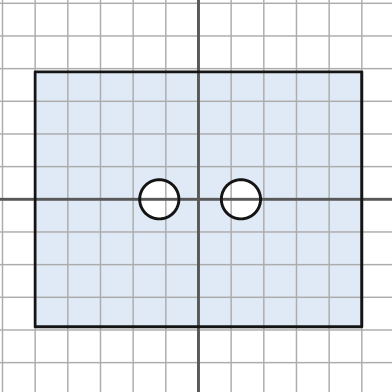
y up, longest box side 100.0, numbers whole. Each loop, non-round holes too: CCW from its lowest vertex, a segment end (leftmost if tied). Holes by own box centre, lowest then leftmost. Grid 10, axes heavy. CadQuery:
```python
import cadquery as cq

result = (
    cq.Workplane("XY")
    .moveTo(-50.0, -39.0)
    .lineTo(50.0, -39.0)
    .lineTo(50.0, 39.0)
    .lineTo(-50.0, 39.0)
    .close()
    .moveTo(-12.0, 0.0)
    .circle(6.0)
    .moveTo(13.0, 0.0)
    .circle(6.0)
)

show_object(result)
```